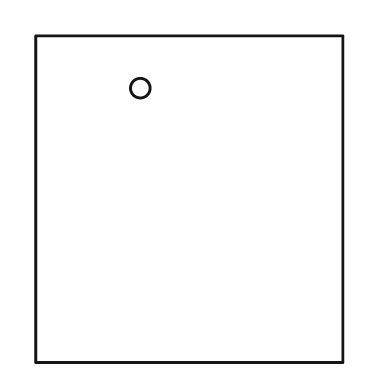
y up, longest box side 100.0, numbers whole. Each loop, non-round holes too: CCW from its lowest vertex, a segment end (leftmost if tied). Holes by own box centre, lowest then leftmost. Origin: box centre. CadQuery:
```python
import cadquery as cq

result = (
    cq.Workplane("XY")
    .moveTo(-47.0, -50.0)
    .lineTo(47.0, -50.0)
    .lineTo(47.0, 50.0)
    .lineTo(-47.0, 50.0)
    .close()
    .moveTo(-15.0, 34.0)
    .circle(3.0)
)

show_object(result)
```